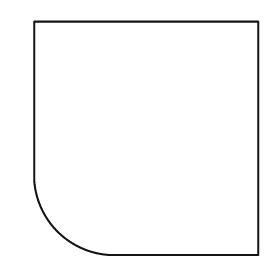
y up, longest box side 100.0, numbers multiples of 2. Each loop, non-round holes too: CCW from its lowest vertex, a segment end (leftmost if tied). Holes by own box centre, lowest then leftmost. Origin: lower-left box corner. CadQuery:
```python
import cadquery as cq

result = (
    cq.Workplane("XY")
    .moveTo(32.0, 0.0)
    .lineTo(96.0, 0.0)
    .lineTo(96.0, 100.0)
    .lineTo(0.0, 100.0)
    .lineTo(0.0, 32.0)
    .threePointArc((10.0, 10.0), (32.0, 0.0))
    .close()
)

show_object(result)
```